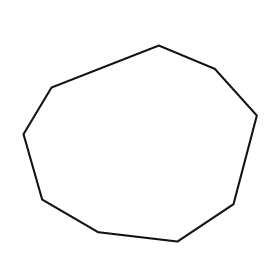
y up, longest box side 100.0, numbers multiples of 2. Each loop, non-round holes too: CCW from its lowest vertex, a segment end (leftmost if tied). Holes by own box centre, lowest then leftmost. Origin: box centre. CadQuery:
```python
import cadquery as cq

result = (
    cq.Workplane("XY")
    .moveTo(16.0, -42.0)
    .lineTo(40.0, -26.0)
    .lineTo(50.0, 12.0)
    .lineTo(32.0, 32.0)
    .lineTo(8.0, 42.0)
    .lineTo(-38.0, 24.0)
    .lineTo(-50.0, 4.0)
    .lineTo(-42.0, -24.0)
    .lineTo(-18.0, -38.0)
    .close()
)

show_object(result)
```